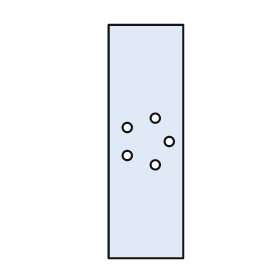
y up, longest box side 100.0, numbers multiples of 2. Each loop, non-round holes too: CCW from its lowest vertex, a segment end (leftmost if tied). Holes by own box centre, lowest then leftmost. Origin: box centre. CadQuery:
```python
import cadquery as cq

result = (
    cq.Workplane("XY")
    .moveTo(-16.0, -50.0)
    .lineTo(16.0, -50.0)
    .lineTo(16.0, 50.0)
    .lineTo(-16.0, 50.0)
    .close()
    .moveTo(4.0, -10.0)
    .circle(2.0)
    .moveTo(-8.0, -6.0)
    .circle(2.0)
    .moveTo(10.0, 0.0)
    .circle(2.0)
    .moveTo(-8.0, 6.0)
    .circle(2.0)
    .moveTo(4.0, 10.0)
    .circle(2.0)
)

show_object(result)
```